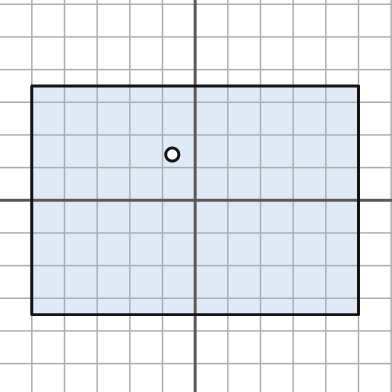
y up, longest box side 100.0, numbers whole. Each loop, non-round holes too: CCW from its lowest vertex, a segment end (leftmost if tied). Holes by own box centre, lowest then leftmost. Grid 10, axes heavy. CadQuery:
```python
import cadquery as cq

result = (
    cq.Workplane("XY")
    .moveTo(-50.0, -35.0)
    .lineTo(50.0, -35.0)
    .lineTo(50.0, 35.0)
    .lineTo(-50.0, 35.0)
    .close()
    .moveTo(-7.0, 14.0)
    .circle(2.0)
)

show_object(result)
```